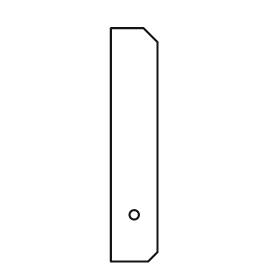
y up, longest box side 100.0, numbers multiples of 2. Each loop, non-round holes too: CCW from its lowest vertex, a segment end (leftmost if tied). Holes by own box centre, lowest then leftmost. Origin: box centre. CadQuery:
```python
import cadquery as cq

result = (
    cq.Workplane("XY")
    .moveTo(-10.0, -50.0)
    .lineTo(6.0, -50.0)
    .lineTo(10.0, -46.0)
    .lineTo(10.0, 44.0)
    .lineTo(4.0, 50.0)
    .lineTo(-10.0, 50.0)
    .close()
    .moveTo(0.0, -30.0)
    .circle(2.0)
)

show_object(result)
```